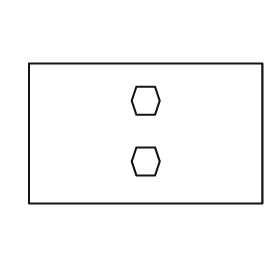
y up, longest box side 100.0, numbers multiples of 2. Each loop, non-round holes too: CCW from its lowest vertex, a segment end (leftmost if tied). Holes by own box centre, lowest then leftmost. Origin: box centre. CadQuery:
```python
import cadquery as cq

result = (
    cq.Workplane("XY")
    .moveTo(-50.0, -30.0)
    .lineTo(50.0, -30.0)
    .lineTo(50.0, 30.0)
    .lineTo(-50.0, 30.0)
    .close()
    .moveTo(-4.0, -18.0)
    .lineTo(4.0, -18.0)
    .lineTo(6.0, -12.0)
    .lineTo(4.0, -6.0)
    .lineTo(-4.0, -6.0)
    .lineTo(-6.0, -12.0)
    .close()
    .moveTo(-4.0, 8.0)
    .lineTo(4.0, 8.0)
    .lineTo(6.0, 14.0)
    .lineTo(4.0, 20.0)
    .lineTo(-4.0, 20.0)
    .lineTo(-6.0, 14.0)
    .close()
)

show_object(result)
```